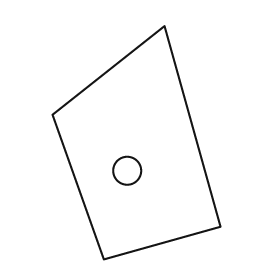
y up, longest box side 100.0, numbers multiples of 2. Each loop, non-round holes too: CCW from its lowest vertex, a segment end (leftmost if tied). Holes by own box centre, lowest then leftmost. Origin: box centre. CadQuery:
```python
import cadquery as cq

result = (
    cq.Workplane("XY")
    .moveTo(-14.0, -50.0)
    .lineTo(36.0, -36.0)
    .lineTo(12.0, 50.0)
    .lineTo(-36.0, 12.0)
    .close()
    .moveTo(-4.0, -12.0)
    .circle(6.0)
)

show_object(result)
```